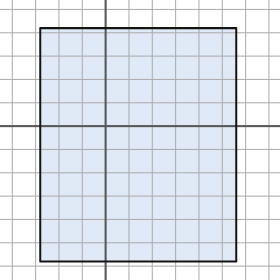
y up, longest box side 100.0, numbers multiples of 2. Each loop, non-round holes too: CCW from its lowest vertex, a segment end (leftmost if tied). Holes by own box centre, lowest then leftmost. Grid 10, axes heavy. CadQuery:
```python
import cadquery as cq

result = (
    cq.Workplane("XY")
    .moveTo(-28.0, -58.0)
    .lineTo(56.0, -58.0)
    .lineTo(56.0, 42.0)
    .lineTo(-28.0, 42.0)
    .close()
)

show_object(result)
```